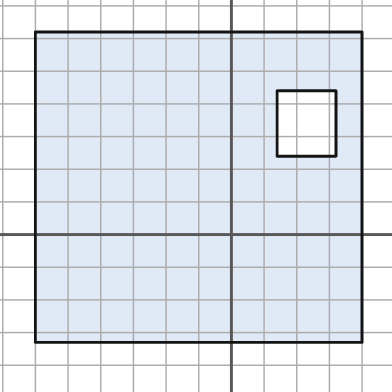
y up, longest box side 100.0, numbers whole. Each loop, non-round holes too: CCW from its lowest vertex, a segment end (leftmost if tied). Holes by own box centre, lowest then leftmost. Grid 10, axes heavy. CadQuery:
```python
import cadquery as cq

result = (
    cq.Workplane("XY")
    .moveTo(-60.0, -33.0)
    .lineTo(40.0, -33.0)
    .lineTo(40.0, 62.0)
    .lineTo(-60.0, 62.0)
    .close()
    .moveTo(14.0, 24.0)
    .lineTo(32.0, 24.0)
    .lineTo(32.0, 44.0)
    .lineTo(14.0, 44.0)
    .close()
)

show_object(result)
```